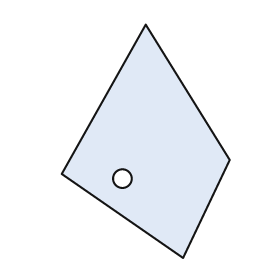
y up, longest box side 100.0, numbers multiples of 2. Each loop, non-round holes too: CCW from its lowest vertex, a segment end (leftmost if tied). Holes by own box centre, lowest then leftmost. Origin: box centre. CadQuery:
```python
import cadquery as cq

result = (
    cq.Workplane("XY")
    .moveTo(16.0, -50.0)
    .lineTo(36.0, -8.0)
    .lineTo(0.0, 50.0)
    .lineTo(-36.0, -14.0)
    .close()
    .moveTo(-10.0, -16.0)
    .circle(4.0)
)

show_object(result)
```